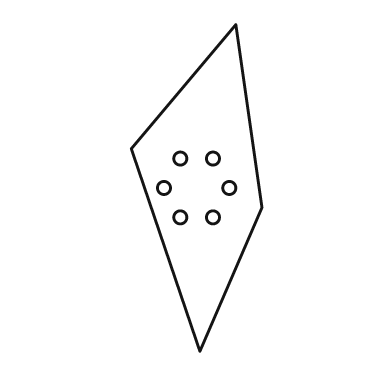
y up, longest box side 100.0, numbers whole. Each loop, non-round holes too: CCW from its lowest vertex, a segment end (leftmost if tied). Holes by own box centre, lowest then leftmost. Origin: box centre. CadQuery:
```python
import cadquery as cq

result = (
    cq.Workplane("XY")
    .moveTo(1.0, -50.0)
    .lineTo(20.0, -6.0)
    .lineTo(12.0, 50.0)
    .lineTo(-20.0, 12.0)
    .close()
    .moveTo(-5.0, -9.0)
    .circle(2.0)
    .moveTo(5.0, -9.0)
    .circle(2.0)
    .moveTo(-10.0, 0.0)
    .circle(2.0)
    .moveTo(10.0, 0.0)
    .circle(2.0)
    .moveTo(-5.0, 9.0)
    .circle(2.0)
    .moveTo(5.0, 9.0)
    .circle(2.0)
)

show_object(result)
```